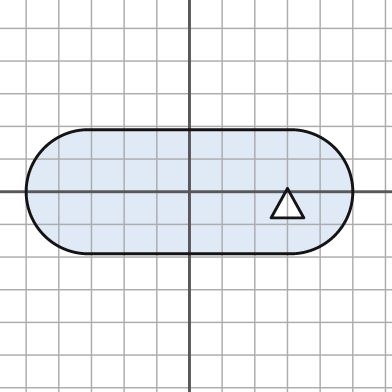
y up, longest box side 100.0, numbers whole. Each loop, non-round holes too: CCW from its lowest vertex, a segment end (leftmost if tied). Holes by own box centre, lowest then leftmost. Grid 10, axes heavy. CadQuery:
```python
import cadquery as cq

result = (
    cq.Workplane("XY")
    .moveTo(-31.0, -19.0)
    .lineTo(31.0, -19.0)
    .threePointArc((50.0, 0.0), (31.0, 19.0))
    .lineTo(-31.0, 19.0)
    .threePointArc((-50.0, 0.0), (-31.0, -19.0))
    .close()
    .moveTo(25.0, -8.0)
    .lineTo(35.0, -8.0)
    .lineTo(30.0, 1.0)
    .close()
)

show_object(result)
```